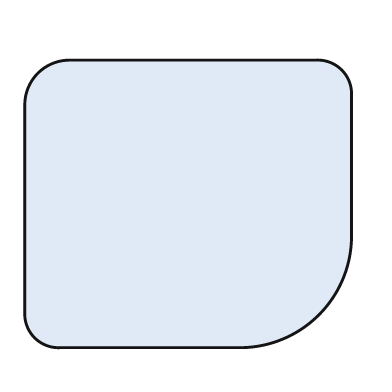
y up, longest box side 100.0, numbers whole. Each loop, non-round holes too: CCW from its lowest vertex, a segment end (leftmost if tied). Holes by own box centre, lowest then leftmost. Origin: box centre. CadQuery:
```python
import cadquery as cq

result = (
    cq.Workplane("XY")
    .moveTo(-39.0, -44.0)
    .lineTo(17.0, -44.0)
    .threePointArc((40.0, -34.0), (50.0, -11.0))
    .lineTo(50.0, 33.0)
    .threePointArc((47.0, 41.0), (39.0, 44.0))
    .lineTo(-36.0, 44.0)
    .threePointArc((-46.0, 40.0), (-50.0, 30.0))
    .lineTo(-50.0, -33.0)
    .threePointArc((-47.0, -41.0), (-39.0, -44.0))
    .close()
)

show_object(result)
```